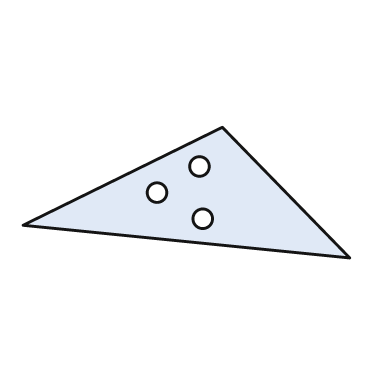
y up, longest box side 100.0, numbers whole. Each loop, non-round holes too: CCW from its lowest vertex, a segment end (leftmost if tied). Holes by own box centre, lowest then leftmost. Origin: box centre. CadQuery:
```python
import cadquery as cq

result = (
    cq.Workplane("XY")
    .moveTo(50.0, -20.0)
    .lineTo(11.0, 20.0)
    .lineTo(-50.0, -10.0)
    .close()
    .moveTo(5.0, -8.0)
    .circle(3.0)
    .moveTo(-9.0, 0.0)
    .circle(3.0)
    .moveTo(4.0, 8.0)
    .circle(3.0)
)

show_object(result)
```